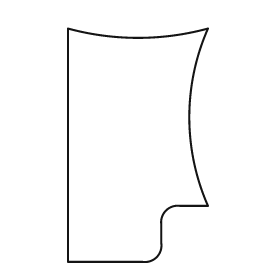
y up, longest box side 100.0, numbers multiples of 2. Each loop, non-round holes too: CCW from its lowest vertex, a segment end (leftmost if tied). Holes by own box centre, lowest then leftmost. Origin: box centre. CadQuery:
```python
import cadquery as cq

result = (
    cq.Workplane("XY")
    .moveTo(-30.0, -50.0)
    .lineTo(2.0, -50.0)
    .threePointArc((8.0, -48.0), (10.0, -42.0))
    .lineTo(10.0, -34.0)
    .threePointArc((12.0, -28.0), (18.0, -26.0))
    .lineTo(30.0, -26.0)
    .threePointArc((22.0, 12.0), (30.0, 50.0))
    .threePointArc((0.0, 46.0), (-30.0, 50.0))
    .close()
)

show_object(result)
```